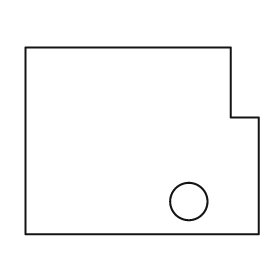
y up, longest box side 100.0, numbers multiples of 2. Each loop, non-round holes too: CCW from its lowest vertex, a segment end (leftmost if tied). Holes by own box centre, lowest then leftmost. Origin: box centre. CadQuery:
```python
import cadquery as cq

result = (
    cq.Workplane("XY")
    .moveTo(-50.0, -40.0)
    .lineTo(50.0, -40.0)
    .lineTo(50.0, 10.0)
    .lineTo(38.0, 10.0)
    .lineTo(38.0, 40.0)
    .lineTo(-50.0, 40.0)
    .close()
    .moveTo(20.0, -26.0)
    .circle(8.0)
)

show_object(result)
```